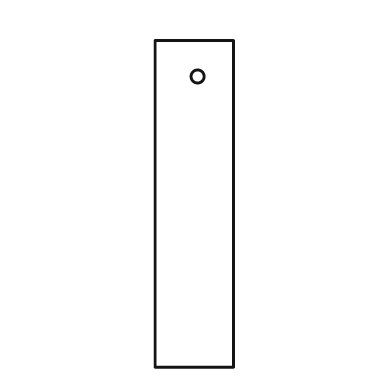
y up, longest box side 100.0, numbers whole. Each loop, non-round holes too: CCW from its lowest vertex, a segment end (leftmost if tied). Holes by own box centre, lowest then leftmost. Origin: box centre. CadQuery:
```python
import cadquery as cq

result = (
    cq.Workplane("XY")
    .moveTo(-12.0, -50.0)
    .lineTo(12.0, -50.0)
    .lineTo(12.0, 50.0)
    .lineTo(-12.0, 50.0)
    .close()
    .moveTo(1.0, 39.0)
    .circle(2.0)
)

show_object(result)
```